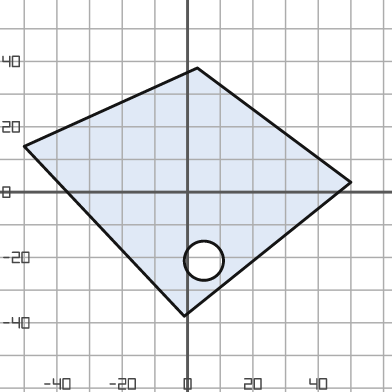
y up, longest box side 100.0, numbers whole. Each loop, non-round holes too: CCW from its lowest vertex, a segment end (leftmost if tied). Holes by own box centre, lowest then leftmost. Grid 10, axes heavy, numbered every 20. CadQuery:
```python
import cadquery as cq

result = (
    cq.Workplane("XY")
    .moveTo(-1.0, -38.0)
    .lineTo(50.0, 3.0)
    .lineTo(3.0, 38.0)
    .lineTo(-50.0, 14.0)
    .close()
    .moveTo(5.0, -21.0)
    .circle(6.0)
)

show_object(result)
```